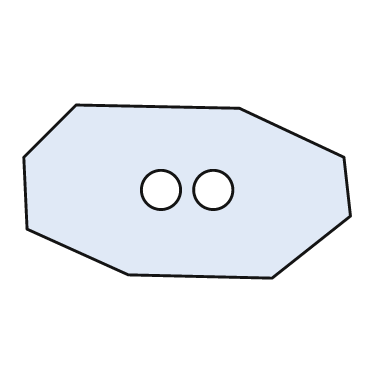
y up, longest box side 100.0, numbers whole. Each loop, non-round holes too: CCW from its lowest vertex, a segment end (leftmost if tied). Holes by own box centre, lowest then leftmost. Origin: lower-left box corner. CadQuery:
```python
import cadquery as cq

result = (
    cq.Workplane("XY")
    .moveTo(76.0, 0.0)
    .lineTo(100.0, 19.0)
    .lineTo(98.0, 37.0)
    .lineTo(66.0, 52.0)
    .lineTo(16.0, 53.0)
    .lineTo(0.0, 37.0)
    .lineTo(1.0, 15.0)
    .lineTo(32.0, 1.0)
    .close()
    .moveTo(42.0, 27.0)
    .circle(6.0)
    .moveTo(58.0, 27.0)
    .circle(6.0)
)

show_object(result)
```